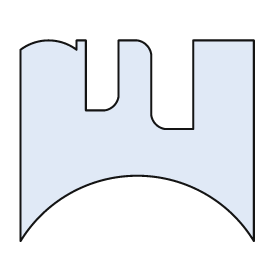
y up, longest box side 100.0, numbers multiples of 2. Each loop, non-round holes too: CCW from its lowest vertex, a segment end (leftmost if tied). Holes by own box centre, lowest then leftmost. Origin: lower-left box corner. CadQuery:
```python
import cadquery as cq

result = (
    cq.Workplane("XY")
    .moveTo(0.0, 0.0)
    .threePointArc((50.0, 28.0), (100.0, 0.0))
    .lineTo(100.0, 86.0)
    .lineTo(74.0, 86.0)
    .lineTo(74.0, 48.0)
    .lineTo(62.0, 48.0)
    .threePointArc((58.0, 50.0), (56.0, 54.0))
    .lineTo(56.0, 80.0)
    .threePointArc((54.0, 84.0), (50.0, 86.0))
    .lineTo(42.0, 86.0)
    .lineTo(42.0, 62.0)
    .threePointArc((40.0, 58.0), (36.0, 56.0))
    .lineTo(28.0, 56.0)
    .lineTo(28.0, 86.0)
    .lineTo(24.0, 86.0)
    .lineTo(24.0, 82.0)
    .threePointArc((12.0, 86.0), (0.0, 82.0))
    .close()
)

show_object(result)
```